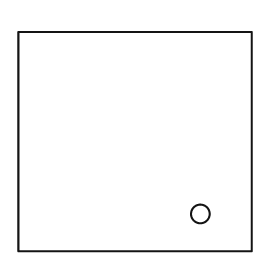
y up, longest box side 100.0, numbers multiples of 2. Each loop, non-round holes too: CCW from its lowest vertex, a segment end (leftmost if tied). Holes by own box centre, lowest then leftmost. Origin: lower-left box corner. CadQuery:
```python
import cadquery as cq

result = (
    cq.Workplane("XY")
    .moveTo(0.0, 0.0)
    .lineTo(100.0, 0.0)
    .lineTo(100.0, 94.0)
    .lineTo(0.0, 94.0)
    .close()
    .moveTo(78.0, 16.0)
    .circle(4.0)
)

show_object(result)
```